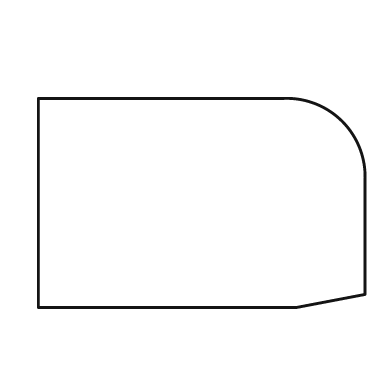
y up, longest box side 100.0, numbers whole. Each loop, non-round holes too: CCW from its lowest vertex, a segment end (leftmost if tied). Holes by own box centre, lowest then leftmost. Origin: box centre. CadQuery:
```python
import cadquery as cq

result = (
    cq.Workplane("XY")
    .moveTo(-50.0, -32.0)
    .lineTo(29.0, -32.0)
    .lineTo(50.0, -28.0)
    .lineTo(50.0, 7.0)
    .threePointArc((43.0, 25.0), (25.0, 32.0))
    .lineTo(-50.0, 32.0)
    .close()
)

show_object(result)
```